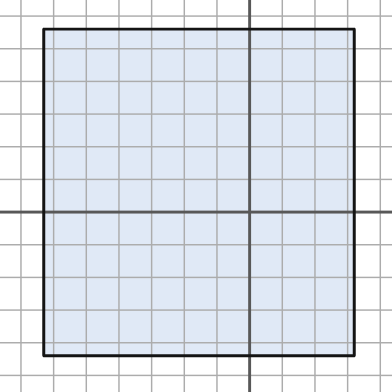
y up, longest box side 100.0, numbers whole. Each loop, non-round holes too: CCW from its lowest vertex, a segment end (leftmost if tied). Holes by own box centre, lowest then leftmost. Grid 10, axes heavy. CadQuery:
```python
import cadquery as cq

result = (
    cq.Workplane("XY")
    .moveTo(-63.0, -44.0)
    .lineTo(32.0, -44.0)
    .lineTo(32.0, 56.0)
    .lineTo(-63.0, 56.0)
    .close()
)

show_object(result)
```